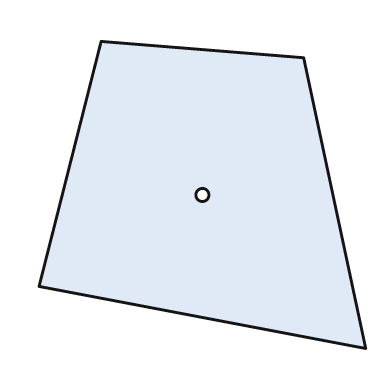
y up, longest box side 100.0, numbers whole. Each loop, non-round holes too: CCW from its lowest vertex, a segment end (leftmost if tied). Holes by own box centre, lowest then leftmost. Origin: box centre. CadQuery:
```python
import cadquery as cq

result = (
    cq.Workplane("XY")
    .moveTo(50.0, -47.0)
    .lineTo(31.0, 42.0)
    .lineTo(-31.0, 47.0)
    .lineTo(-50.0, -28.0)
    .close()
    .moveTo(0.0, 0.0)
    .circle(2.0)
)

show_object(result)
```